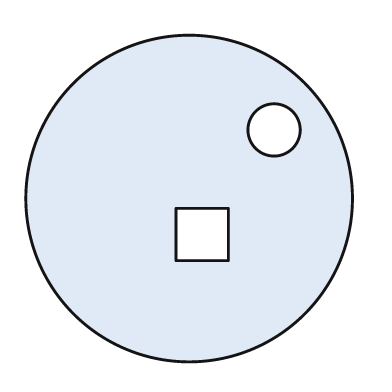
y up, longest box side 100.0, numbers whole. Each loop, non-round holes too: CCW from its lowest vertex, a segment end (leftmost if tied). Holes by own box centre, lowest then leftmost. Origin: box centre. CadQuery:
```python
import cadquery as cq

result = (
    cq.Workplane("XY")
    .moveTo(0.0, 0.0)
    .circle(50.0)
    .moveTo(-4.0, -19.0)
    .lineTo(12.0, -19.0)
    .lineTo(12.0, -3.0)
    .lineTo(-4.0, -3.0)
    .close()
    .moveTo(26.0, 21.0)
    .circle(8.0)
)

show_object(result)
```